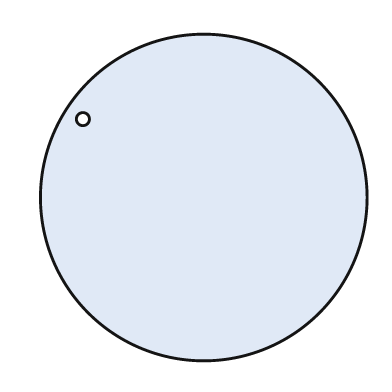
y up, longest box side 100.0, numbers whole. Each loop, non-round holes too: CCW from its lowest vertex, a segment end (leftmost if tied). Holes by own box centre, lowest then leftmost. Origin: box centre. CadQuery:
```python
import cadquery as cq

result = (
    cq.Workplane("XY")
    .moveTo(0.0, 0.0)
    .circle(50.0)
    .moveTo(-37.0, 24.0)
    .circle(2.0)
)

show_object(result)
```